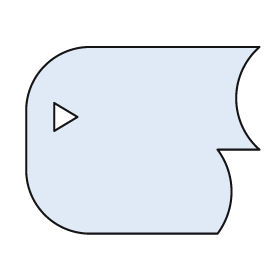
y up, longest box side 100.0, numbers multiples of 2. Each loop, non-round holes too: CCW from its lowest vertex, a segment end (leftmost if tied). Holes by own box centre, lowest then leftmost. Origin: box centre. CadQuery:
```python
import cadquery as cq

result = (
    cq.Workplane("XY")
    .moveTo(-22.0, -40.0)
    .lineTo(32.0, -40.0)
    .threePointArc((38.0, -22.0), (32.0, -4.0))
    .lineTo(50.0, -4.0)
    .threePointArc((40.0, 18.0), (50.0, 40.0))
    .lineTo(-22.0, 40.0)
    .threePointArc((-42.0, 32.0), (-50.0, 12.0))
    .lineTo(-50.0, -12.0)
    .threePointArc((-42.0, -32.0), (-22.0, -40.0))
    .close()
    .moveTo(-38.0, 4.0)
    .lineTo(-28.0, 10.0)
    .lineTo(-38.0, 16.0)
    .close()
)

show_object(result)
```